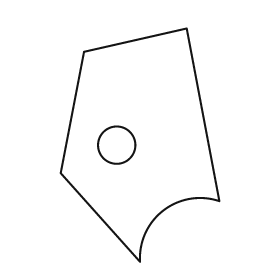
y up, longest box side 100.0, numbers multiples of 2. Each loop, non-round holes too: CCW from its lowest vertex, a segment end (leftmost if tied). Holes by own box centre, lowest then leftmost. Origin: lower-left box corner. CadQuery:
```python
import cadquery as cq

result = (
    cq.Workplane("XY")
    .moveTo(34.0, 0.0)
    .threePointArc((44.0, 22.0), (68.0, 26.0))
    .lineTo(54.0, 100.0)
    .lineTo(10.0, 90.0)
    .lineTo(0.0, 38.0)
    .close()
    .moveTo(24.0, 50.0)
    .circle(8.0)
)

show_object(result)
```